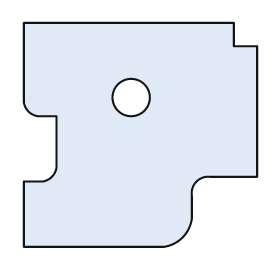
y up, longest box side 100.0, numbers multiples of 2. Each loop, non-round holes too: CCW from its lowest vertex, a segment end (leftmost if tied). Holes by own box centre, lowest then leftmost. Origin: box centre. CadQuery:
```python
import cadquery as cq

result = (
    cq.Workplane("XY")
    .moveTo(-50.0, -48.0)
    .lineTo(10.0, -48.0)
    .threePointArc((18.0, -44.0), (22.0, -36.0))
    .lineTo(22.0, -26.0)
    .threePointArc((24.0, -20.0), (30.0, -18.0))
    .lineTo(50.0, -18.0)
    .lineTo(50.0, 38.0)
    .lineTo(40.0, 38.0)
    .lineTo(40.0, 48.0)
    .lineTo(-50.0, 48.0)
    .lineTo(-50.0, 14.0)
    .threePointArc((-48.0, 10.0), (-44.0, 8.0))
    .lineTo(-36.0, 8.0)
    .lineTo(-36.0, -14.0)
    .threePointArc((-38.0, -18.0), (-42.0, -20.0))
    .lineTo(-50.0, -20.0)
    .close()
    .moveTo(-4.0, 16.0)
    .circle(8.0)
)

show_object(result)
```